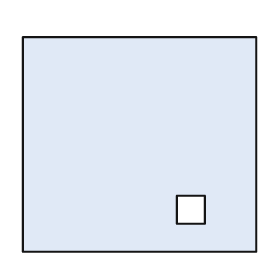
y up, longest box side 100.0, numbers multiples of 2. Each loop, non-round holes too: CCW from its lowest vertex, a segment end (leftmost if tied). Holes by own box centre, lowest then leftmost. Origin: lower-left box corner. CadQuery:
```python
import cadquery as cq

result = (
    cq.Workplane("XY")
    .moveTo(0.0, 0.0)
    .lineTo(100.0, 0.0)
    .lineTo(100.0, 92.0)
    .lineTo(0.0, 92.0)
    .close()
    .moveTo(66.0, 12.0)
    .lineTo(78.0, 12.0)
    .lineTo(78.0, 24.0)
    .lineTo(66.0, 24.0)
    .close()
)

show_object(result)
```